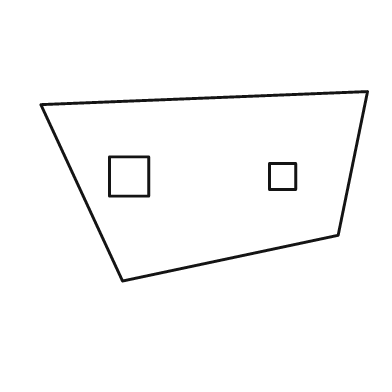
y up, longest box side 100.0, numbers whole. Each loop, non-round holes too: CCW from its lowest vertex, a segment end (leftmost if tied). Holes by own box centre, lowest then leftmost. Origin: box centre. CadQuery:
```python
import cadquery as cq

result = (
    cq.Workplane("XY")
    .moveTo(-25.0, -29.0)
    .lineTo(41.0, -15.0)
    .lineTo(50.0, 29.0)
    .lineTo(-50.0, 25.0)
    .close()
    .moveTo(-29.0, -3.0)
    .lineTo(-17.0, -3.0)
    .lineTo(-17.0, 9.0)
    .lineTo(-29.0, 9.0)
    .close()
    .moveTo(20.0, -1.0)
    .lineTo(28.0, -1.0)
    .lineTo(28.0, 7.0)
    .lineTo(20.0, 7.0)
    .close()
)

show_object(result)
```